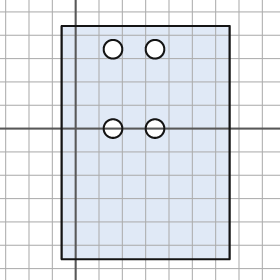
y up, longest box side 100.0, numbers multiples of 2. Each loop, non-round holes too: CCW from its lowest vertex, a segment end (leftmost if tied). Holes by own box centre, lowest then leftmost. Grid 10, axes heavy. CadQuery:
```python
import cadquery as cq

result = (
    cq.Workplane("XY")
    .moveTo(-6.0, -56.0)
    .lineTo(66.0, -56.0)
    .lineTo(66.0, 44.0)
    .lineTo(-6.0, 44.0)
    .close()
    .moveTo(16.0, 0.0)
    .circle(4.0)
    .moveTo(34.0, 0.0)
    .circle(4.0)
    .moveTo(16.0, 34.0)
    .circle(4.0)
    .moveTo(34.0, 34.0)
    .circle(4.0)
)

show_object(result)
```